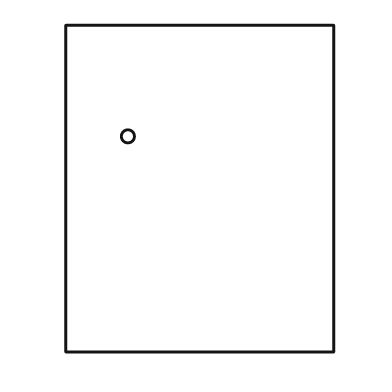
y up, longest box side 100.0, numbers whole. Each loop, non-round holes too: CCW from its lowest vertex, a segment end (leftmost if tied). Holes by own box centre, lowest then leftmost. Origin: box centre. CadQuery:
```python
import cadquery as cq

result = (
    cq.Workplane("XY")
    .moveTo(-41.0, -50.0)
    .lineTo(41.0, -50.0)
    .lineTo(41.0, 50.0)
    .lineTo(-41.0, 50.0)
    .close()
    .moveTo(-22.0, 16.0)
    .circle(2.0)
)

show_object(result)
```